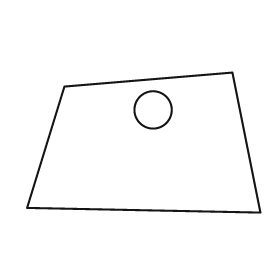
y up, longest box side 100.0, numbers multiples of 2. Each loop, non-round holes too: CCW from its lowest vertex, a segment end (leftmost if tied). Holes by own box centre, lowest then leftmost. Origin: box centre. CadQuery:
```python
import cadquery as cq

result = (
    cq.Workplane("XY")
    .moveTo(50.0, -30.0)
    .lineTo(38.0, 30.0)
    .lineTo(-34.0, 24.0)
    .lineTo(-50.0, -28.0)
    .close()
    .moveTo(4.0, 14.0)
    .circle(8.0)
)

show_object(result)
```